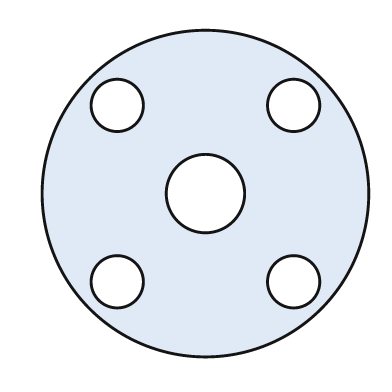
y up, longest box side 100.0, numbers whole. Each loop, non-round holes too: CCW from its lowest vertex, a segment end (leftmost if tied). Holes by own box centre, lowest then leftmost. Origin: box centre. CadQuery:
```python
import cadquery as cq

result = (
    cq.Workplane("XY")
    .moveTo(0.0, 0.0)
    .circle(50.0)
    .moveTo(-27.0, -27.0)
    .circle(8.0)
    .moveTo(27.0, -27.0)
    .circle(8.0)
    .moveTo(0.0, 0.0)
    .circle(12.0)
    .moveTo(-27.0, 27.0)
    .circle(8.0)
    .moveTo(27.0, 27.0)
    .circle(8.0)
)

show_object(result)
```